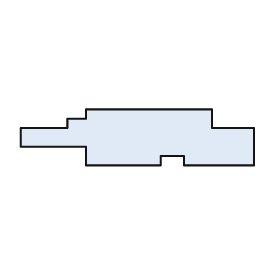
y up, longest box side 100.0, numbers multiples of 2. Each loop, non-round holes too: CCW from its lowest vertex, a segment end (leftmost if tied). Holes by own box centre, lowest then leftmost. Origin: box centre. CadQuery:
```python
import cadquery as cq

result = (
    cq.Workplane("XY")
    .moveTo(-22.0, -12.0)
    .lineTo(10.0, -12.0)
    .lineTo(10.0, -8.0)
    .lineTo(20.0, -8.0)
    .lineTo(20.0, -12.0)
    .lineTo(50.0, -12.0)
    .lineTo(50.0, 4.0)
    .lineTo(32.0, 4.0)
    .lineTo(32.0, 12.0)
    .lineTo(-22.0, 12.0)
    .lineTo(-22.0, 8.0)
    .lineTo(-30.0, 8.0)
    .lineTo(-30.0, 4.0)
    .lineTo(-50.0, 4.0)
    .lineTo(-50.0, -4.0)
    .lineTo(-22.0, -4.0)
    .close()
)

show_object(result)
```